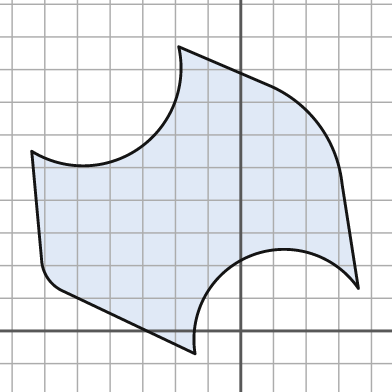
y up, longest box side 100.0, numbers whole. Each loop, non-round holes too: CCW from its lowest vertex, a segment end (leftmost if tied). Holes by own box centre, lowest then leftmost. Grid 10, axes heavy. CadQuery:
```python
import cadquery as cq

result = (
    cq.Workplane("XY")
    .moveTo(-14.0, -7.0)
    .threePointArc((3.0, 23.0), (36.0, 13.0))
    .lineTo(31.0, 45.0)
    .threePointArc((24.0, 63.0), (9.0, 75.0))
    .lineTo(-19.0, 87.0)
    .threePointArc((-31.0, 56.0), (-64.0, 55.0))
    .lineTo(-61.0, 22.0)
    .threePointArc((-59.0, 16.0), (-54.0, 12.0))
    .close()
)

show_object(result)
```